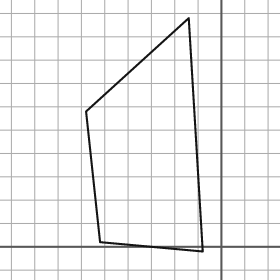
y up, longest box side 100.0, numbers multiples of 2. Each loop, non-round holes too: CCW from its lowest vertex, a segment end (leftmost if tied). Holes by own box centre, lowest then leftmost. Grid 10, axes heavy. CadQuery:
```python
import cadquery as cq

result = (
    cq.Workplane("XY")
    .moveTo(-8.0, -2.0)
    .lineTo(-14.0, 98.0)
    .lineTo(-58.0, 58.0)
    .lineTo(-52.0, 2.0)
    .close()
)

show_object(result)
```